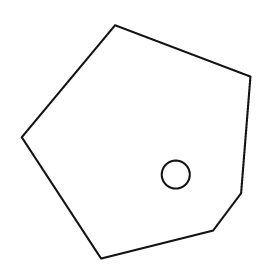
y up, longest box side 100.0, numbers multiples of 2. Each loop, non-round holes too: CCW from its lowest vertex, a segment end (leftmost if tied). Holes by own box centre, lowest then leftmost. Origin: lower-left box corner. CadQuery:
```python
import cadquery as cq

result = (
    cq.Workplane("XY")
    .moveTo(34.0, 0.0)
    .lineTo(82.0, 12.0)
    .lineTo(94.0, 28.0)
    .lineTo(98.0, 78.0)
    .lineTo(40.0, 100.0)
    .lineTo(0.0, 52.0)
    .close()
    .moveTo(66.0, 36.0)
    .circle(6.0)
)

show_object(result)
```